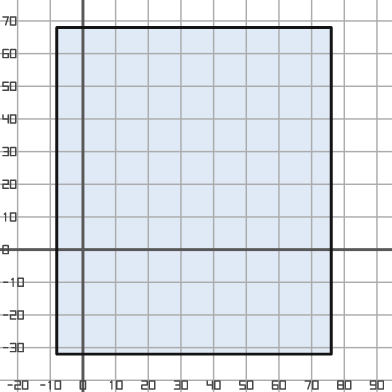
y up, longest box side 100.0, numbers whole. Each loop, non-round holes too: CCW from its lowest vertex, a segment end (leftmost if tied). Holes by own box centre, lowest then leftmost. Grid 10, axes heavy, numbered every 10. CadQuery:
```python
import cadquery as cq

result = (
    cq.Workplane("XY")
    .moveTo(-8.0, -32.0)
    .lineTo(76.0, -32.0)
    .lineTo(76.0, 68.0)
    .lineTo(-8.0, 68.0)
    .close()
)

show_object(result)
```